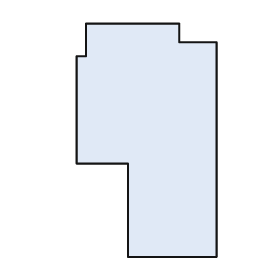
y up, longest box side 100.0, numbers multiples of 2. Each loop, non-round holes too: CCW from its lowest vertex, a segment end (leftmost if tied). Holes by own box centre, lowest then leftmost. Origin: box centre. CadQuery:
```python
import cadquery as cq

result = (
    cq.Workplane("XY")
    .moveTo(-8.0, -50.0)
    .lineTo(30.0, -50.0)
    .lineTo(30.0, 42.0)
    .lineTo(14.0, 42.0)
    .lineTo(14.0, 50.0)
    .lineTo(-26.0, 50.0)
    .lineTo(-26.0, 36.0)
    .lineTo(-30.0, 36.0)
    .lineTo(-30.0, -10.0)
    .lineTo(-8.0, -10.0)
    .close()
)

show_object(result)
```